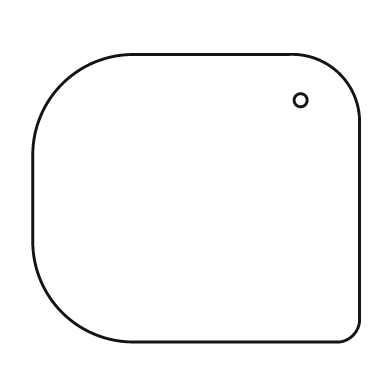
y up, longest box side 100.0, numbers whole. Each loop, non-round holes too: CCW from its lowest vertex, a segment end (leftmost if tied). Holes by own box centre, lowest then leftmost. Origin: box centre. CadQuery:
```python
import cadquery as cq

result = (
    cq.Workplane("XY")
    .moveTo(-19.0, -44.0)
    .lineTo(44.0, -44.0)
    .threePointArc((48.0, -42.0), (50.0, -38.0))
    .lineTo(50.0, 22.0)
    .threePointArc((44.0, 38.0), (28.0, 44.0))
    .lineTo(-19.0, 44.0)
    .threePointArc((-41.0, 35.0), (-50.0, 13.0))
    .lineTo(-50.0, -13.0)
    .threePointArc((-41.0, -35.0), (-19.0, -44.0))
    .close()
    .moveTo(32.0, 30.0)
    .circle(2.0)
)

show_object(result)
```